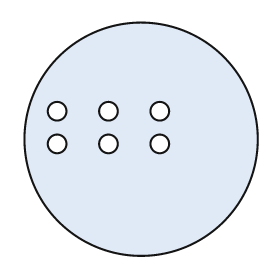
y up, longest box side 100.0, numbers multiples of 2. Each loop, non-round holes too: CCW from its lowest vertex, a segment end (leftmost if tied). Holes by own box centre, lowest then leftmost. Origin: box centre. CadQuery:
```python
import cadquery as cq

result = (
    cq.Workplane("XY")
    .moveTo(0.0, 0.0)
    .circle(50.0)
    .moveTo(-36.0, -2.0)
    .circle(4.0)
    .moveTo(-14.0, -2.0)
    .circle(4.0)
    .moveTo(8.0, -2.0)
    .circle(4.0)
    .moveTo(-36.0, 12.0)
    .circle(4.0)
    .moveTo(-14.0, 12.0)
    .circle(4.0)
    .moveTo(8.0, 12.0)
    .circle(4.0)
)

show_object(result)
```